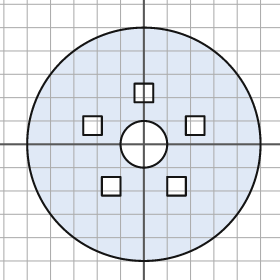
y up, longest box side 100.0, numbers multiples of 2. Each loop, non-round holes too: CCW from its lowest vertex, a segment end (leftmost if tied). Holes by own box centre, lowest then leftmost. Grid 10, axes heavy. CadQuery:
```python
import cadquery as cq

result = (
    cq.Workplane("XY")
    .moveTo(0.0, 0.0)
    .circle(50.0)
    .moveTo(-18.0, -22.0)
    .lineTo(-10.0, -22.0)
    .lineTo(-10.0, -14.0)
    .lineTo(-18.0, -14.0)
    .close()
    .moveTo(10.0, -22.0)
    .lineTo(18.0, -22.0)
    .lineTo(18.0, -14.0)
    .lineTo(10.0, -14.0)
    .close()
    .moveTo(0.0, 0.0)
    .circle(10.0)
    .moveTo(-26.0, 4.0)
    .lineTo(-18.0, 4.0)
    .lineTo(-18.0, 12.0)
    .lineTo(-26.0, 12.0)
    .close()
    .moveTo(18.0, 4.0)
    .lineTo(26.0, 4.0)
    .lineTo(26.0, 12.0)
    .lineTo(18.0, 12.0)
    .close()
    .moveTo(-4.0, 18.0)
    .lineTo(4.0, 18.0)
    .lineTo(4.0, 26.0)
    .lineTo(-4.0, 26.0)
    .close()
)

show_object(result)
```